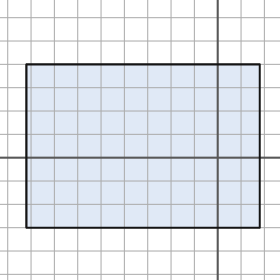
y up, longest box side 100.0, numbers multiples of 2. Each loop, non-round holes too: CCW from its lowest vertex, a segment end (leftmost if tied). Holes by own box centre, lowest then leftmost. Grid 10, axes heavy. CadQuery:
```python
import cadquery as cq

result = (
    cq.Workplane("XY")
    .moveTo(-82.0, -30.0)
    .lineTo(18.0, -30.0)
    .lineTo(18.0, 40.0)
    .lineTo(-82.0, 40.0)
    .close()
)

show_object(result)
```